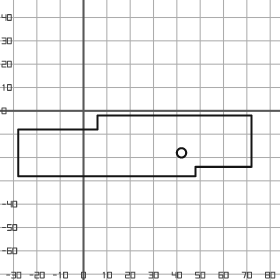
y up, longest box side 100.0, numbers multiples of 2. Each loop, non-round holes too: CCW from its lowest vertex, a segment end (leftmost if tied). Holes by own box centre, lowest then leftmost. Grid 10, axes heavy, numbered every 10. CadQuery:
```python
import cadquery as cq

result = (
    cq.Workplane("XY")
    .moveTo(-28.0, -28.0)
    .lineTo(48.0, -28.0)
    .lineTo(48.0, -24.0)
    .lineTo(72.0, -24.0)
    .lineTo(72.0, -2.0)
    .lineTo(6.0, -2.0)
    .lineTo(6.0, -8.0)
    .lineTo(-28.0, -8.0)
    .close()
    .moveTo(42.0, -18.0)
    .circle(2.0)
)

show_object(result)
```